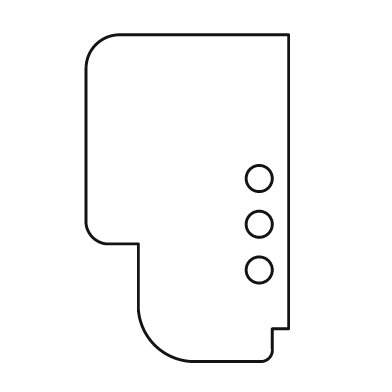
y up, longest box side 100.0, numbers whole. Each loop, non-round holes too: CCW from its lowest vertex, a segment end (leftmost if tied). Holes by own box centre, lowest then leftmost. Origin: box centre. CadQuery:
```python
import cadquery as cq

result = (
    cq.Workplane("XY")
    .moveTo(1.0, -50.0)
    .lineTo(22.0, -50.0)
    .threePointArc((25.0, -49.0), (26.0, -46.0))
    .lineTo(26.0, -40.0)
    .lineTo(31.0, -40.0)
    .lineTo(31.0, 50.0)
    .lineTo(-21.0, 50.0)
    .threePointArc((-28.0, 47.0), (-31.0, 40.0))
    .lineTo(-31.0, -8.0)
    .threePointArc((-29.0, -12.0), (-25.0, -14.0))
    .lineTo(-15.0, -14.0)
    .lineTo(-15.0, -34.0)
    .threePointArc((-10.0, -45.0), (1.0, -50.0))
    .close()
    .moveTo(22.0, -22.0)
    .circle(4.0)
    .moveTo(22.0, -8.0)
    .circle(4.0)
    .moveTo(22.0, 6.0)
    .circle(4.0)
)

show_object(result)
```